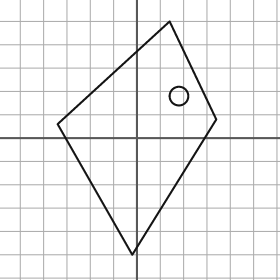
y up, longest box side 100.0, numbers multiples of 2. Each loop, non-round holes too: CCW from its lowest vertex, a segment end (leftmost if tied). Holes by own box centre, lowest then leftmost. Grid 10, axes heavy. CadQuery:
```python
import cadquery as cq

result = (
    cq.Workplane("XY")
    .moveTo(-2.0, -50.0)
    .lineTo(34.0, 8.0)
    .lineTo(14.0, 50.0)
    .lineTo(-34.0, 6.0)
    .close()
    .moveTo(18.0, 18.0)
    .circle(4.0)
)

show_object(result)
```